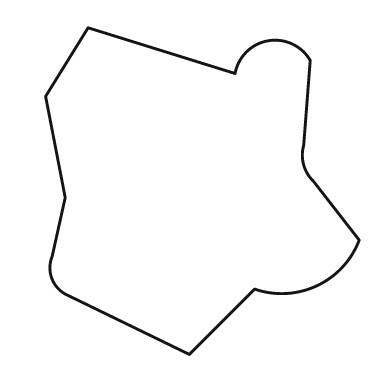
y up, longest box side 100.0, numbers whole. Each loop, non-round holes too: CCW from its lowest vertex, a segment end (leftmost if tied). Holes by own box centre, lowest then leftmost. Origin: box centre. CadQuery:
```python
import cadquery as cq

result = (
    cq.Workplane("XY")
    .moveTo(-4.0, -50.0)
    .lineTo(16.0, -30.0)
    .threePointArc((35.0, -29.0), (48.0, -15.0))
    .lineTo(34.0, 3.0)
    .threePointArc((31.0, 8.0), (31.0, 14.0))
    .lineTo(33.0, 40.0)
    .threePointArc((20.0, 46.0), (10.0, 36.0))
    .lineTo(-35.0, 50.0)
    .lineTo(-48.0, 29.0)
    .lineTo(-42.0, -2.0)
    .lineTo(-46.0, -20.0)
    .threePointArc((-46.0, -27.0), (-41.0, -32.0))
    .close()
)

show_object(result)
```